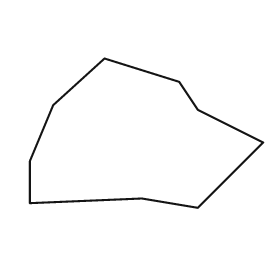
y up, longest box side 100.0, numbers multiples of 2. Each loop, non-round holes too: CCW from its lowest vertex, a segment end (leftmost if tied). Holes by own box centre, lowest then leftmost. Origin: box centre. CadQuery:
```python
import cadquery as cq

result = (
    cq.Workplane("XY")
    .moveTo(22.0, -32.0)
    .lineTo(50.0, -4.0)
    .lineTo(22.0, 10.0)
    .lineTo(14.0, 22.0)
    .lineTo(-18.0, 32.0)
    .lineTo(-40.0, 12.0)
    .lineTo(-50.0, -12.0)
    .lineTo(-50.0, -30.0)
    .lineTo(-2.0, -28.0)
    .close()
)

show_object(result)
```